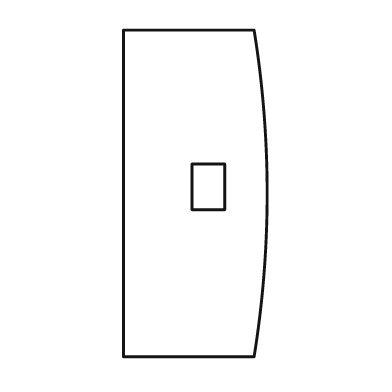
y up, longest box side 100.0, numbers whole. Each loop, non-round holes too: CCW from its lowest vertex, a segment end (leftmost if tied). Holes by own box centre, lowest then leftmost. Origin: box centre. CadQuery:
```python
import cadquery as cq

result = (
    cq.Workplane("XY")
    .moveTo(-22.0, -50.0)
    .lineTo(18.0, -50.0)
    .threePointArc((22.0, 0.0), (18.0, 50.0))
    .lineTo(-22.0, 50.0)
    .close()
    .moveTo(-1.0, -5.0)
    .lineTo(9.0, -5.0)
    .lineTo(9.0, 9.0)
    .lineTo(-1.0, 9.0)
    .close()
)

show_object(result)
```